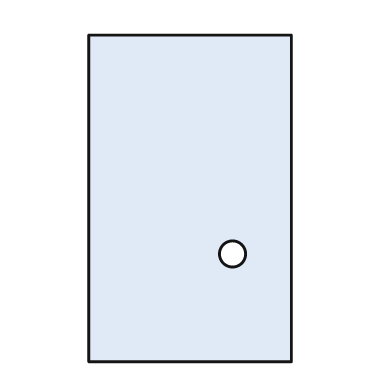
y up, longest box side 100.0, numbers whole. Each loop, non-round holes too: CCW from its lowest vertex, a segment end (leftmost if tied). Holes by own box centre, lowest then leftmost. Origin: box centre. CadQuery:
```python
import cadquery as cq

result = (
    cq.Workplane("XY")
    .moveTo(-31.0, -50.0)
    .lineTo(31.0, -50.0)
    .lineTo(31.0, 50.0)
    .lineTo(-31.0, 50.0)
    .close()
    .moveTo(13.0, -17.0)
    .circle(4.0)
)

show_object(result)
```